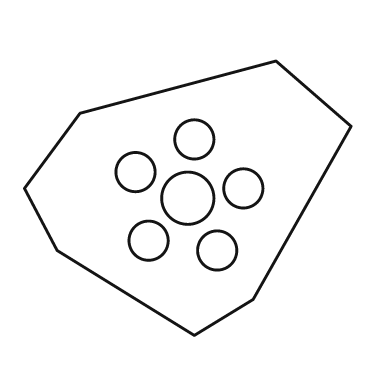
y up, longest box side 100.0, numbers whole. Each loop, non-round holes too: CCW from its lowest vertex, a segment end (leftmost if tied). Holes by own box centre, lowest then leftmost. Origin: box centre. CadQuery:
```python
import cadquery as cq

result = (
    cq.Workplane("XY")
    .moveTo(2.0, -42.0)
    .lineTo(20.0, -31.0)
    .lineTo(50.0, 22.0)
    .lineTo(27.0, 42.0)
    .lineTo(-33.0, 26.0)
    .lineTo(-50.0, 3.0)
    .lineTo(-40.0, -16.0)
    .close()
    .moveTo(9.0, -16.0)
    .circle(6.0)
    .moveTo(-12.0, -13.0)
    .circle(6.0)
    .moveTo(0.0, 0.0)
    .circle(8.0)
    .moveTo(17.0, 3.0)
    .circle(6.0)
    .moveTo(-16.0, 8.0)
    .circle(6.0)
    .moveTo(2.0, 18.0)
    .circle(6.0)
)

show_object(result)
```